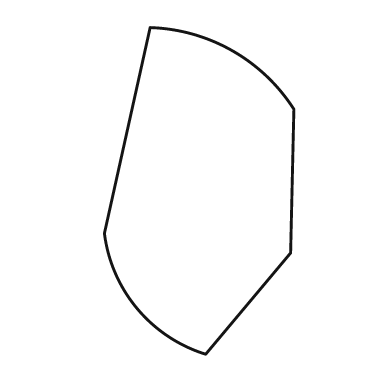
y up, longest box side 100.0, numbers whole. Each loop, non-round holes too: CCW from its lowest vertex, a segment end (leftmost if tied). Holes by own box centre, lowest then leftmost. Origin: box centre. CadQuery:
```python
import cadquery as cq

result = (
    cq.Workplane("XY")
    .moveTo(2.0, -50.0)
    .lineTo(28.0, -19.0)
    .lineTo(29.0, 25.0)
    .threePointArc((10.0, 43.0), (-15.0, 50.0))
    .lineTo(-29.0, -13.0)
    .threePointArc((-19.0, -36.0), (2.0, -50.0))
    .close()
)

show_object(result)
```